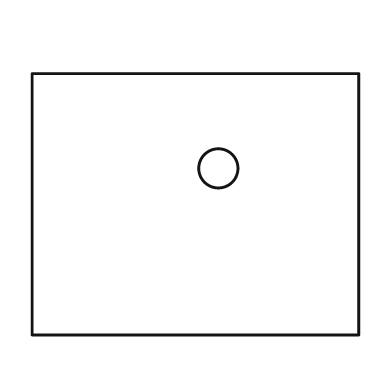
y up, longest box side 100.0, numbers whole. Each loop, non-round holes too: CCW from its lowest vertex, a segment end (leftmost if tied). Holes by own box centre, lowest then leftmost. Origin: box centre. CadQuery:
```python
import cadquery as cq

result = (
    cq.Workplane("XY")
    .moveTo(-50.0, -40.0)
    .lineTo(50.0, -40.0)
    .lineTo(50.0, 40.0)
    .lineTo(-50.0, 40.0)
    .close()
    .moveTo(7.0, 11.0)
    .circle(6.0)
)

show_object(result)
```